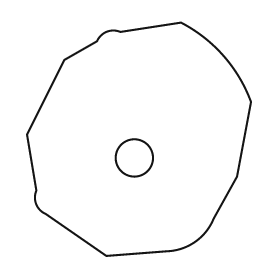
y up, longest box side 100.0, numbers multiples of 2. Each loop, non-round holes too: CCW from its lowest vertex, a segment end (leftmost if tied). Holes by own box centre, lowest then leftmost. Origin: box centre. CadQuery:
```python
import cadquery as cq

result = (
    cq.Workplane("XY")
    .moveTo(-14.0, -50.0)
    .lineTo(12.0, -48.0)
    .threePointArc((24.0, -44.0), (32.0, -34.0))
    .lineTo(42.0, -16.0)
    .lineTo(48.0, 16.0)
    .threePointArc((36.0, 36.0), (18.0, 50.0))
    .lineTo(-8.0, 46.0)
    .threePointArc((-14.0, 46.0), (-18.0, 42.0))
    .lineTo(-32.0, 34.0)
    .lineTo(-48.0, 2.0)
    .lineTo(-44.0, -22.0)
    .threePointArc((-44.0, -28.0), (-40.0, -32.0))
    .close()
    .moveTo(-2.0, -8.0)
    .circle(8.0)
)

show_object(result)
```